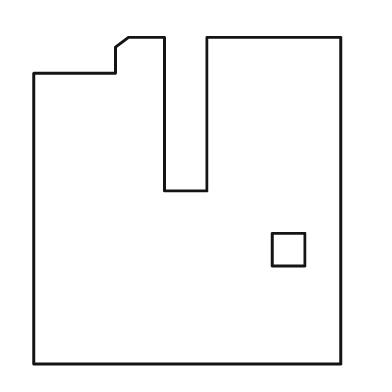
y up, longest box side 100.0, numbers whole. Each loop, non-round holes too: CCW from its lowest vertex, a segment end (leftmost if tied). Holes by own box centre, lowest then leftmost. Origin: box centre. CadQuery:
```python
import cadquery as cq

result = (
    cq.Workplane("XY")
    .moveTo(-47.0, -50.0)
    .lineTo(47.0, -50.0)
    .lineTo(47.0, 50.0)
    .lineTo(6.0, 50.0)
    .lineTo(6.0, 3.0)
    .lineTo(-7.0, 3.0)
    .lineTo(-7.0, 50.0)
    .lineTo(-18.0, 50.0)
    .lineTo(-22.0, 47.0)
    .lineTo(-22.0, 39.0)
    .lineTo(-47.0, 39.0)
    .close()
    .moveTo(26.0, -20.0)
    .lineTo(36.0, -20.0)
    .lineTo(36.0, -10.0)
    .lineTo(26.0, -10.0)
    .close()
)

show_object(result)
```